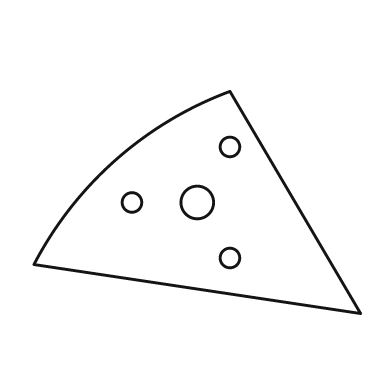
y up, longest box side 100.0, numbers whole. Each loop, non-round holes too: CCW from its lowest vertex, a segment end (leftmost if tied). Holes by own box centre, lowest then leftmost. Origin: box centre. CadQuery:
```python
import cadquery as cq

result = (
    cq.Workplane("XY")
    .moveTo(50.0, -34.0)
    .lineTo(10.0, 34.0)
    .threePointArc((-25.0, 13.0), (-50.0, -19.0))
    .close()
    .moveTo(10.0, -17.0)
    .circle(3.0)
    .moveTo(-20.0, 0.0)
    .circle(3.0)
    .moveTo(0.0, 0.0)
    .circle(5.0)
    .moveTo(10.0, 17.0)
    .circle(3.0)
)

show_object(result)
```